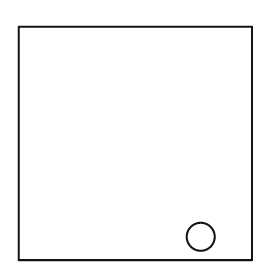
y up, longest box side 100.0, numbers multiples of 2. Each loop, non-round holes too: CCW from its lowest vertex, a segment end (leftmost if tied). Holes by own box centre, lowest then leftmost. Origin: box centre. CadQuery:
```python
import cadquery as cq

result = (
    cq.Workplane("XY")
    .moveTo(-50.0, -50.0)
    .lineTo(50.0, -50.0)
    .lineTo(50.0, 50.0)
    .lineTo(-50.0, 50.0)
    .close()
    .moveTo(28.0, -40.0)
    .circle(6.0)
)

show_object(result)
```